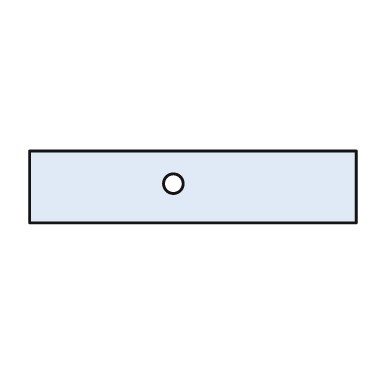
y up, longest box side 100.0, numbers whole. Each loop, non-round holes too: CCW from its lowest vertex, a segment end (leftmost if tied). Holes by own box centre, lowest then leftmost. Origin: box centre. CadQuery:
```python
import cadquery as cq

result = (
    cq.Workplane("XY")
    .moveTo(-50.0, -11.0)
    .lineTo(50.0, -11.0)
    .lineTo(50.0, 11.0)
    .lineTo(-50.0, 11.0)
    .close()
    .moveTo(-6.0, 1.0)
    .circle(3.0)
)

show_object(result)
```